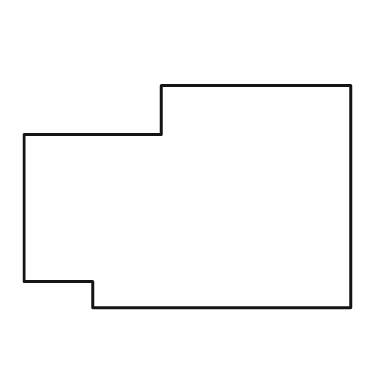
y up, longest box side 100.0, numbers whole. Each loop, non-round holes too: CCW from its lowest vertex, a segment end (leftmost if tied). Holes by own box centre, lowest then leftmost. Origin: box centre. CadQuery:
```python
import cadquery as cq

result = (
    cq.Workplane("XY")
    .moveTo(-29.0, -34.0)
    .lineTo(50.0, -34.0)
    .lineTo(50.0, 34.0)
    .lineTo(-8.0, 34.0)
    .lineTo(-8.0, 19.0)
    .lineTo(-50.0, 19.0)
    .lineTo(-50.0, -26.0)
    .lineTo(-29.0, -26.0)
    .close()
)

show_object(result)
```